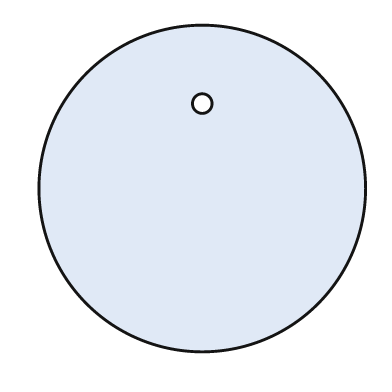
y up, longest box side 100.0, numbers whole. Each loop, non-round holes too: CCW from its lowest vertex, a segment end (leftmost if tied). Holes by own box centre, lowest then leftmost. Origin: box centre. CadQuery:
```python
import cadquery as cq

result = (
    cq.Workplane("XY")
    .moveTo(0.0, 0.0)
    .circle(50.0)
    .moveTo(0.0, 26.0)
    .circle(3.0)
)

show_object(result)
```